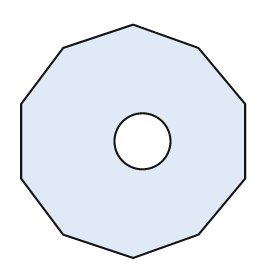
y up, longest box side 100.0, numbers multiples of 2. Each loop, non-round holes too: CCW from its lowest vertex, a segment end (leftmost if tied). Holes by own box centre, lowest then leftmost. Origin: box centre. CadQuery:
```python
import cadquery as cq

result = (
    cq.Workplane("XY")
    .moveTo(0.0, -50.0)
    .lineTo(28.0, -40.0)
    .lineTo(48.0, -16.0)
    .lineTo(48.0, 16.0)
    .lineTo(28.0, 40.0)
    .lineTo(0.0, 50.0)
    .lineTo(-30.0, 40.0)
    .lineTo(-48.0, 16.0)
    .lineTo(-48.0, -16.0)
    .lineTo(-30.0, -40.0)
    .close()
    .moveTo(4.0, 0.0)
    .circle(12.0)
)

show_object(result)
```